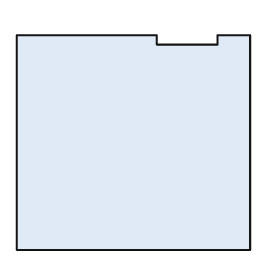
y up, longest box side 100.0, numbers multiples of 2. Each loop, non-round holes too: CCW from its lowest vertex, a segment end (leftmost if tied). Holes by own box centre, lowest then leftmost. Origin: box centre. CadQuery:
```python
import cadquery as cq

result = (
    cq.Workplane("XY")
    .moveTo(-50.0, -46.0)
    .lineTo(50.0, -46.0)
    .lineTo(50.0, 46.0)
    .lineTo(36.0, 46.0)
    .lineTo(36.0, 42.0)
    .lineTo(10.0, 42.0)
    .lineTo(10.0, 46.0)
    .lineTo(-50.0, 46.0)
    .close()
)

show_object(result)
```